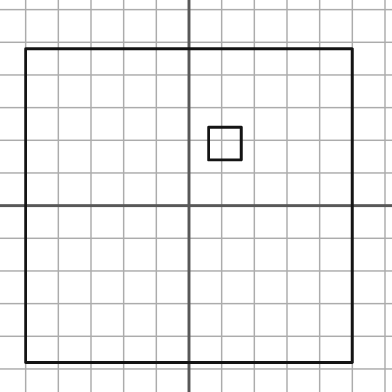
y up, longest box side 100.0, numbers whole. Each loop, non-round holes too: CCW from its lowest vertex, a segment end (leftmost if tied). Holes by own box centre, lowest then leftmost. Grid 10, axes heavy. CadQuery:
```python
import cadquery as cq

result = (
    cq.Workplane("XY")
    .moveTo(-50.0, -48.0)
    .lineTo(50.0, -48.0)
    .lineTo(50.0, 48.0)
    .lineTo(-50.0, 48.0)
    .close()
    .moveTo(6.0, 14.0)
    .lineTo(16.0, 14.0)
    .lineTo(16.0, 24.0)
    .lineTo(6.0, 24.0)
    .close()
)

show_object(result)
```